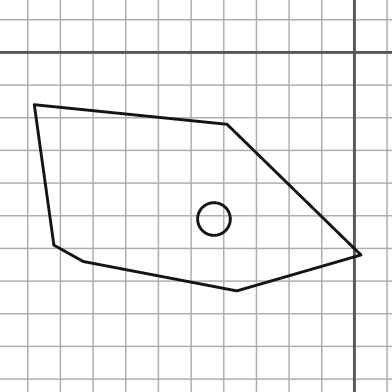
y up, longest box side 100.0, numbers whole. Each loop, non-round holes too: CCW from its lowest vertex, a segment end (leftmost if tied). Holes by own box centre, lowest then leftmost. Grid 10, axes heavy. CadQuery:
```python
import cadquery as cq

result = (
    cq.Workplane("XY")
    .moveTo(-36.0, -73.0)
    .lineTo(2.0, -62.0)
    .lineTo(-39.0, -22.0)
    .lineTo(-98.0, -16.0)
    .lineTo(-92.0, -59.0)
    .lineTo(-83.0, -64.0)
    .close()
    .moveTo(-43.0, -51.0)
    .circle(5.0)
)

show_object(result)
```